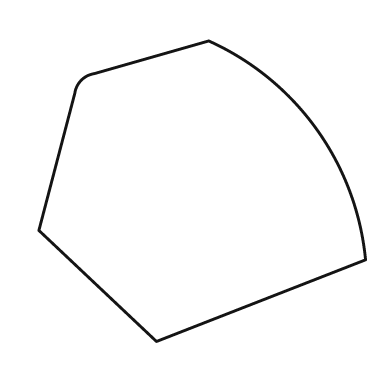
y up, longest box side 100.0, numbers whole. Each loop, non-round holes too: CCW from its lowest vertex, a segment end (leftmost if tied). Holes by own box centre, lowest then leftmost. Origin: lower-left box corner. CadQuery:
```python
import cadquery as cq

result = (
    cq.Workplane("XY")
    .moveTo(36.0, 0.0)
    .lineTo(100.0, 25.0)
    .threePointArc((85.0, 65.0), (52.0, 92.0))
    .lineTo(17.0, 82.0)
    .threePointArc((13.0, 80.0), (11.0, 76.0))
    .lineTo(0.0, 34.0)
    .close()
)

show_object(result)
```